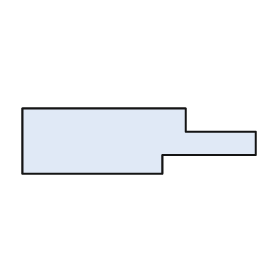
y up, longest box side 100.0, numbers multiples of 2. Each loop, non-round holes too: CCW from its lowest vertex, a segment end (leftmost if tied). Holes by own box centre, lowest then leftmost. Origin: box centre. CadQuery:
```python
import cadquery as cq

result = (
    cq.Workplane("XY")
    .moveTo(-50.0, -14.0)
    .lineTo(10.0, -14.0)
    .lineTo(10.0, -6.0)
    .lineTo(50.0, -6.0)
    .lineTo(50.0, 4.0)
    .lineTo(20.0, 4.0)
    .lineTo(20.0, 14.0)
    .lineTo(-50.0, 14.0)
    .close()
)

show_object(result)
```